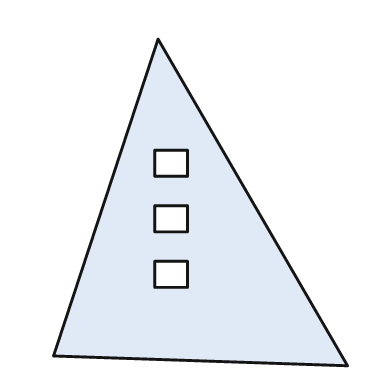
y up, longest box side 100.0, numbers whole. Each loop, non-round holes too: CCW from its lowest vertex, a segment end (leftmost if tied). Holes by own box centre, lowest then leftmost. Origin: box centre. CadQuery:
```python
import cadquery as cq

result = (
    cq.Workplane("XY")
    .moveTo(45.0, -50.0)
    .lineTo(-13.0, 50.0)
    .lineTo(-45.0, -47.0)
    .close()
    .moveTo(-14.0, -26.0)
    .lineTo(-4.0, -26.0)
    .lineTo(-4.0, -18.0)
    .lineTo(-14.0, -18.0)
    .close()
    .moveTo(-14.0, -9.0)
    .lineTo(-4.0, -9.0)
    .lineTo(-4.0, -1.0)
    .lineTo(-14.0, -1.0)
    .close()
    .moveTo(-14.0, 8.0)
    .lineTo(-4.0, 8.0)
    .lineTo(-4.0, 16.0)
    .lineTo(-14.0, 16.0)
    .close()
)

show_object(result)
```